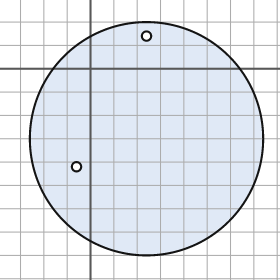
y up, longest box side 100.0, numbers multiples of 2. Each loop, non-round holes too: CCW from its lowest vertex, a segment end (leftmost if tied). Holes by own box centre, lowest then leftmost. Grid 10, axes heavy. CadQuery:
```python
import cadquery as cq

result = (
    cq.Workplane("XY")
    .moveTo(24.0, -30.0)
    .circle(50.0)
    .moveTo(-6.0, -42.0)
    .circle(2.0)
    .moveTo(24.0, 14.0)
    .circle(2.0)
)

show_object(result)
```